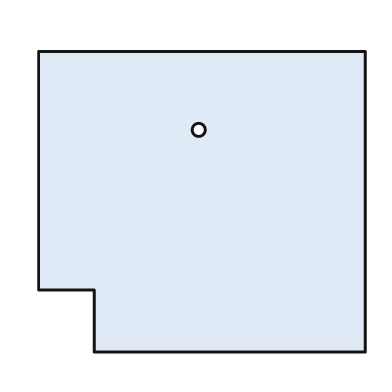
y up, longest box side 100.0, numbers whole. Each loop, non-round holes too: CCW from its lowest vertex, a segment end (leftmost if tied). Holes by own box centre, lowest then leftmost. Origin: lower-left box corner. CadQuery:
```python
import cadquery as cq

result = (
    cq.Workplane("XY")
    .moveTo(17.0, 0.0)
    .lineTo(100.0, 0.0)
    .lineTo(100.0, 92.0)
    .lineTo(0.0, 92.0)
    .lineTo(0.0, 19.0)
    .lineTo(17.0, 19.0)
    .close()
    .moveTo(49.0, 68.0)
    .circle(2.0)
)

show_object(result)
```